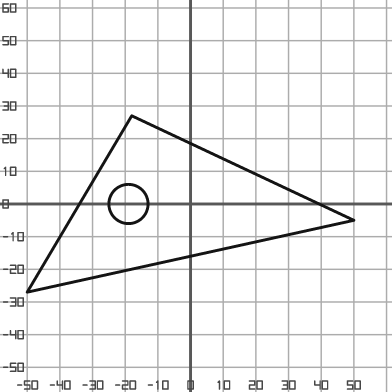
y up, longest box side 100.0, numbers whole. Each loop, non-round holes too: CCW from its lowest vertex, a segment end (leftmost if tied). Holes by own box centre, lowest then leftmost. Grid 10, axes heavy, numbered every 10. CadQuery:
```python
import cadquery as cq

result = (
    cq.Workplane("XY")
    .moveTo(-50.0, -27.0)
    .lineTo(50.0, -5.0)
    .lineTo(-18.0, 27.0)
    .close()
    .moveTo(-19.0, 0.0)
    .circle(6.0)
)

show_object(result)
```